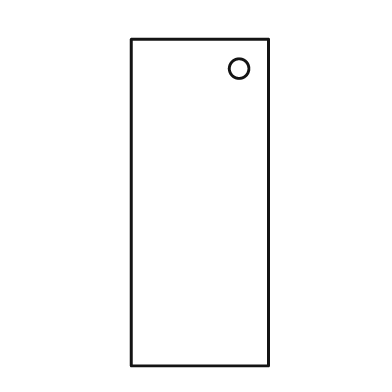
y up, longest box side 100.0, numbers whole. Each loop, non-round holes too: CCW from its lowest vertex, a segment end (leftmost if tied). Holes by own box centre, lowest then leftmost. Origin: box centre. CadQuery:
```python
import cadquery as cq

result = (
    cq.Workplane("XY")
    .moveTo(-21.0, -50.0)
    .lineTo(21.0, -50.0)
    .lineTo(21.0, 50.0)
    .lineTo(-21.0, 50.0)
    .close()
    .moveTo(12.0, 41.0)
    .circle(3.0)
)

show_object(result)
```